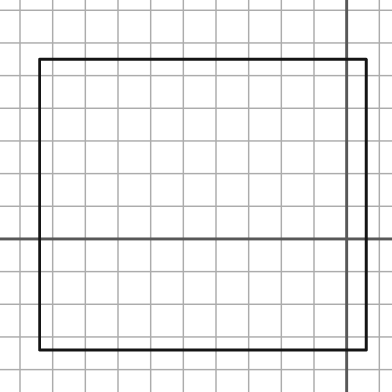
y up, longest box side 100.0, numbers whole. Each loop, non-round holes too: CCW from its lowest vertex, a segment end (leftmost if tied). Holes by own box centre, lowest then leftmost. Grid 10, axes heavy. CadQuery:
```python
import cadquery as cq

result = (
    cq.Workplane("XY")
    .moveTo(-94.0, -34.0)
    .lineTo(6.0, -34.0)
    .lineTo(6.0, 55.0)
    .lineTo(-94.0, 55.0)
    .close()
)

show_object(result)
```